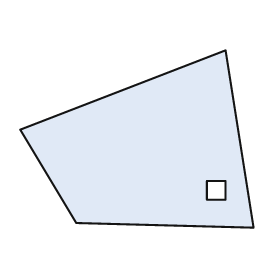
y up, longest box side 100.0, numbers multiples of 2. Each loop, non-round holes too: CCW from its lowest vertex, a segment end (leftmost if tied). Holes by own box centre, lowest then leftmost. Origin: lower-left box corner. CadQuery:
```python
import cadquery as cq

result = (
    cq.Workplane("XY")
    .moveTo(100.0, 0.0)
    .lineTo(88.0, 76.0)
    .lineTo(0.0, 42.0)
    .lineTo(24.0, 2.0)
    .close()
    .moveTo(80.0, 12.0)
    .lineTo(88.0, 12.0)
    .lineTo(88.0, 20.0)
    .lineTo(80.0, 20.0)
    .close()
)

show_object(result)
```